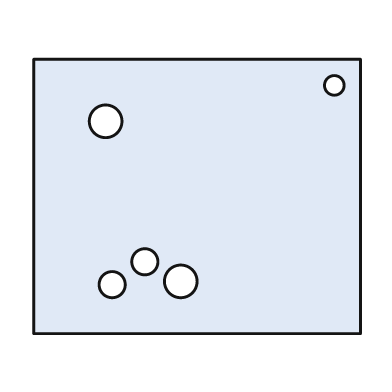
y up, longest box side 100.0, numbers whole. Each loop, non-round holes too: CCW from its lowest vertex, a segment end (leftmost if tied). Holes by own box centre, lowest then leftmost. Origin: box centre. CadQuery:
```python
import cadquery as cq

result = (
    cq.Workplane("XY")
    .moveTo(-50.0, -42.0)
    .lineTo(50.0, -42.0)
    .lineTo(50.0, 42.0)
    .lineTo(-50.0, 42.0)
    .close()
    .moveTo(-26.0, -27.0)
    .circle(4.0)
    .moveTo(-5.0, -26.0)
    .circle(5.0)
    .moveTo(-16.0, -20.0)
    .circle(4.0)
    .moveTo(-28.0, 23.0)
    .circle(5.0)
    .moveTo(42.0, 34.0)
    .circle(3.0)
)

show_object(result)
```